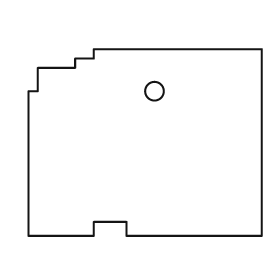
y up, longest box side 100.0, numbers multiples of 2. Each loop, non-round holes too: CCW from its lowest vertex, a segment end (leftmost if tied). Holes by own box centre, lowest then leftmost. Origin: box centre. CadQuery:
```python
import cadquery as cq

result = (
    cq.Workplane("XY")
    .moveTo(-50.0, -40.0)
    .lineTo(-22.0, -40.0)
    .lineTo(-22.0, -34.0)
    .lineTo(-8.0, -34.0)
    .lineTo(-8.0, -40.0)
    .lineTo(50.0, -40.0)
    .lineTo(50.0, 40.0)
    .lineTo(-22.0, 40.0)
    .lineTo(-22.0, 36.0)
    .lineTo(-30.0, 36.0)
    .lineTo(-30.0, 32.0)
    .lineTo(-46.0, 32.0)
    .lineTo(-46.0, 22.0)
    .lineTo(-50.0, 22.0)
    .close()
    .moveTo(4.0, 22.0)
    .circle(4.0)
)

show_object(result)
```